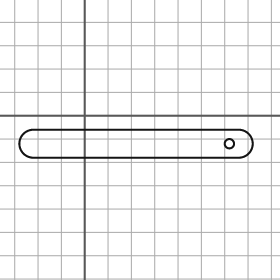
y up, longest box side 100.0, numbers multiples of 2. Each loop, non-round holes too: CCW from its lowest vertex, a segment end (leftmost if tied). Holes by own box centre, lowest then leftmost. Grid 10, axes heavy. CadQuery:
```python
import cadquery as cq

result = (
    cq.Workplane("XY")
    .moveTo(-22.0, -18.0)
    .lineTo(66.0, -18.0)
    .threePointArc((72.0, -12.0), (66.0, -6.0))
    .lineTo(-22.0, -6.0)
    .threePointArc((-28.0, -12.0), (-22.0, -18.0))
    .close()
    .moveTo(62.0, -12.0)
    .circle(2.0)
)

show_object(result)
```